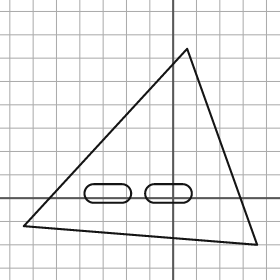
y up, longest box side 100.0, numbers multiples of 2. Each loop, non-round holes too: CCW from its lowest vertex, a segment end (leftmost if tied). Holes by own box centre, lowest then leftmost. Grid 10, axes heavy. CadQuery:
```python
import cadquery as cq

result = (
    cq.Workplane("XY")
    .moveTo(36.0, -20.0)
    .lineTo(6.0, 64.0)
    .lineTo(-64.0, -12.0)
    .close()
    .moveTo(-34.0, -2.0)
    .lineTo(-22.0, -2.0)
    .threePointArc((-18.0, 2.0), (-22.0, 6.0))
    .lineTo(-34.0, 6.0)
    .threePointArc((-38.0, 2.0), (-34.0, -2.0))
    .close()
    .moveTo(-8.0, -2.0)
    .lineTo(4.0, -2.0)
    .threePointArc((8.0, 2.0), (4.0, 6.0))
    .lineTo(-8.0, 6.0)
    .threePointArc((-12.0, 2.0), (-8.0, -2.0))
    .close()
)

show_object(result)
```